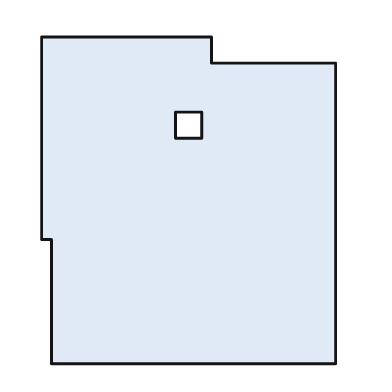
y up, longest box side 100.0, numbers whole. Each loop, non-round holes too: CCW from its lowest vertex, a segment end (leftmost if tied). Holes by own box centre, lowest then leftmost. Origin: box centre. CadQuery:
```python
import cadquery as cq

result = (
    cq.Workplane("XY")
    .moveTo(-42.0, -50.0)
    .lineTo(45.0, -50.0)
    .lineTo(45.0, 42.0)
    .lineTo(7.0, 42.0)
    .lineTo(7.0, 50.0)
    .lineTo(-45.0, 50.0)
    .lineTo(-45.0, -12.0)
    .lineTo(-42.0, -12.0)
    .close()
    .moveTo(-4.0, 19.0)
    .lineTo(4.0, 19.0)
    .lineTo(4.0, 27.0)
    .lineTo(-4.0, 27.0)
    .close()
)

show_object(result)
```